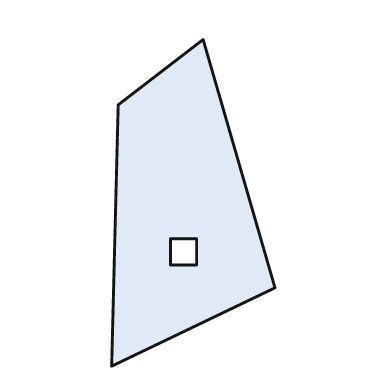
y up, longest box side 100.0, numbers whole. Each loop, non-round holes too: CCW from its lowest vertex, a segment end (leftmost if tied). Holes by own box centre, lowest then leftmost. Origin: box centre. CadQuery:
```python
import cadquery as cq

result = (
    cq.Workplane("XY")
    .moveTo(-25.0, -50.0)
    .lineTo(25.0, -26.0)
    .lineTo(3.0, 50.0)
    .lineTo(-23.0, 30.0)
    .close()
    .moveTo(-7.0, -19.0)
    .lineTo(1.0, -19.0)
    .lineTo(1.0, -11.0)
    .lineTo(-7.0, -11.0)
    .close()
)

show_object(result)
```